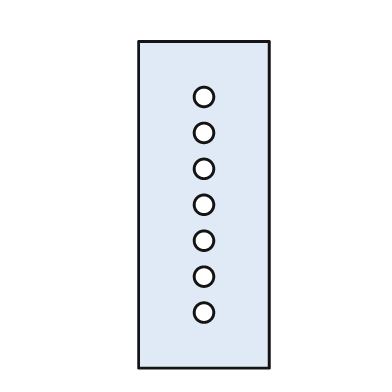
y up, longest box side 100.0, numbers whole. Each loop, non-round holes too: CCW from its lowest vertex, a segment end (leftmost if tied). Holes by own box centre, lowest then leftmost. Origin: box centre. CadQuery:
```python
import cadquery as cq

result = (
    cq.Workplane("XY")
    .moveTo(-20.0, -50.0)
    .lineTo(20.0, -50.0)
    .lineTo(20.0, 50.0)
    .lineTo(-20.0, 50.0)
    .close()
    .moveTo(0.0, -33.0)
    .circle(3.0)
    .moveTo(0.0, -22.0)
    .circle(3.0)
    .moveTo(0.0, -11.0)
    .circle(3.0)
    .moveTo(0.0, 0.0)
    .circle(3.0)
    .moveTo(0.0, 11.0)
    .circle(3.0)
    .moveTo(0.0, 22.0)
    .circle(3.0)
    .moveTo(0.0, 33.0)
    .circle(3.0)
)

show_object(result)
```